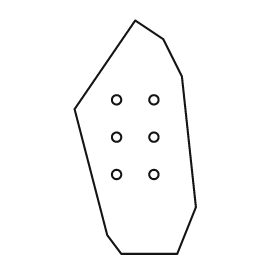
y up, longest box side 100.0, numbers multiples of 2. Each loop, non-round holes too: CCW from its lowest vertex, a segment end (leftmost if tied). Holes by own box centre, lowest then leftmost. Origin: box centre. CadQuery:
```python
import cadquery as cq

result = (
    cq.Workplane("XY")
    .moveTo(-6.0, -50.0)
    .lineTo(18.0, -50.0)
    .lineTo(26.0, -30.0)
    .lineTo(20.0, 26.0)
    .lineTo(12.0, 42.0)
    .lineTo(0.0, 50.0)
    .lineTo(-26.0, 12.0)
    .lineTo(-12.0, -42.0)
    .close()
    .moveTo(-8.0, -16.0)
    .circle(2.0)
    .moveTo(8.0, -16.0)
    .circle(2.0)
    .moveTo(-8.0, 0.0)
    .circle(2.0)
    .moveTo(8.0, 0.0)
    .circle(2.0)
    .moveTo(-8.0, 16.0)
    .circle(2.0)
    .moveTo(8.0, 16.0)
    .circle(2.0)
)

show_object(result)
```